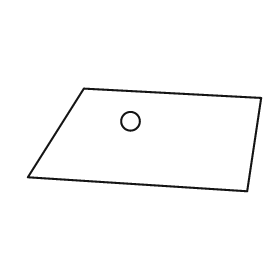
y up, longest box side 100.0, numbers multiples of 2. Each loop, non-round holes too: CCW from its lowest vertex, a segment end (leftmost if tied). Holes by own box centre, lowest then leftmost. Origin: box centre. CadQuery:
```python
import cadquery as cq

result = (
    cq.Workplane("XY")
    .moveTo(44.0, -22.0)
    .lineTo(50.0, 18.0)
    .lineTo(-26.0, 22.0)
    .lineTo(-50.0, -16.0)
    .close()
    .moveTo(-6.0, 8.0)
    .circle(4.0)
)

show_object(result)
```